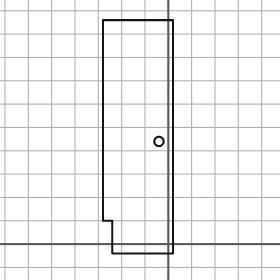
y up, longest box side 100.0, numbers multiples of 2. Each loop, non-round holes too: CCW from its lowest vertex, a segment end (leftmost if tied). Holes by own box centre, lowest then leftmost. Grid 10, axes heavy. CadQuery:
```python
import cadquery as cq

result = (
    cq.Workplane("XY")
    .moveTo(-24.0, -4.0)
    .lineTo(2.0, -4.0)
    .lineTo(2.0, 96.0)
    .lineTo(-28.0, 96.0)
    .lineTo(-28.0, 10.0)
    .lineTo(-24.0, 10.0)
    .close()
    .moveTo(-4.0, 44.0)
    .circle(2.0)
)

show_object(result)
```